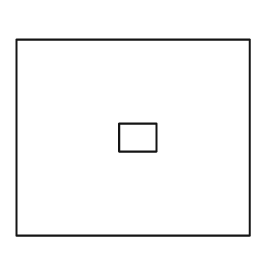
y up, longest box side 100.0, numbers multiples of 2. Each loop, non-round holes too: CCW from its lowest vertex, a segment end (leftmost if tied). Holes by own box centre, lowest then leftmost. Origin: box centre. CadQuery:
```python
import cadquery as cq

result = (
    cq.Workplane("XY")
    .moveTo(-50.0, -42.0)
    .lineTo(50.0, -42.0)
    .lineTo(50.0, 42.0)
    .lineTo(-50.0, 42.0)
    .close()
    .moveTo(-6.0, -6.0)
    .lineTo(10.0, -6.0)
    .lineTo(10.0, 6.0)
    .lineTo(-6.0, 6.0)
    .close()
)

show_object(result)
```